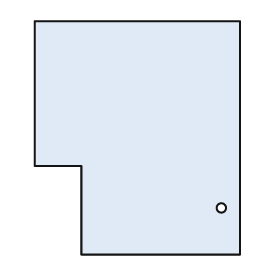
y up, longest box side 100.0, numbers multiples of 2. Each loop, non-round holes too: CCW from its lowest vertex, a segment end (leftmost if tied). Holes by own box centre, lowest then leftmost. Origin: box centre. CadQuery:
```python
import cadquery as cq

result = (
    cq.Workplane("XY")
    .moveTo(-24.0, -50.0)
    .lineTo(44.0, -50.0)
    .lineTo(44.0, 50.0)
    .lineTo(-44.0, 50.0)
    .lineTo(-44.0, -12.0)
    .lineTo(-24.0, -12.0)
    .close()
    .moveTo(36.0, -30.0)
    .circle(2.0)
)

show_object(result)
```